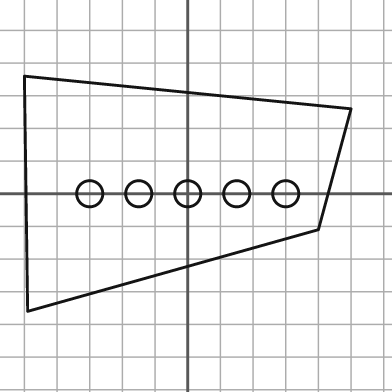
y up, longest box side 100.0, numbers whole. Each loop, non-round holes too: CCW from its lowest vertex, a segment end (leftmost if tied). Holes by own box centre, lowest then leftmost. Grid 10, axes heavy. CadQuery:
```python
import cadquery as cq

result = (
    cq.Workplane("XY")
    .moveTo(-49.0, -36.0)
    .lineTo(40.0, -11.0)
    .lineTo(50.0, 26.0)
    .lineTo(-50.0, 36.0)
    .close()
    .moveTo(-30.0, 0.0)
    .circle(4.0)
    .moveTo(-15.0, 0.0)
    .circle(4.0)
    .moveTo(0.0, 0.0)
    .circle(4.0)
    .moveTo(15.0, 0.0)
    .circle(4.0)
    .moveTo(30.0, 0.0)
    .circle(4.0)
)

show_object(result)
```